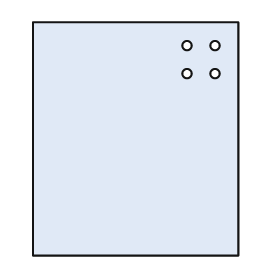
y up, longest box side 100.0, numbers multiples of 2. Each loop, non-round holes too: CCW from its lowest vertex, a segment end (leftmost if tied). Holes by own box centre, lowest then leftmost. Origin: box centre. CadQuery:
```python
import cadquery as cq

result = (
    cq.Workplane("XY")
    .moveTo(-44.0, -50.0)
    .lineTo(44.0, -50.0)
    .lineTo(44.0, 50.0)
    .lineTo(-44.0, 50.0)
    .close()
    .moveTo(22.0, 28.0)
    .circle(2.0)
    .moveTo(34.0, 28.0)
    .circle(2.0)
    .moveTo(22.0, 40.0)
    .circle(2.0)
    .moveTo(34.0, 40.0)
    .circle(2.0)
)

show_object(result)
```